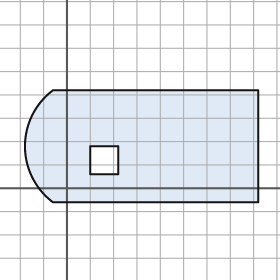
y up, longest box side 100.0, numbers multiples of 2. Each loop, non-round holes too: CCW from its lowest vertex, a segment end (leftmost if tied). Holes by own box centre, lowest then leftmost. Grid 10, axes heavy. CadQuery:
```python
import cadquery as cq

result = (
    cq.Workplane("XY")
    .moveTo(-6.0, -6.0)
    .lineTo(82.0, -6.0)
    .lineTo(82.0, 42.0)
    .lineTo(-6.0, 42.0)
    .threePointArc((-18.0, 18.0), (-6.0, -6.0))
    .close()
    .moveTo(10.0, 6.0)
    .lineTo(22.0, 6.0)
    .lineTo(22.0, 18.0)
    .lineTo(10.0, 18.0)
    .close()
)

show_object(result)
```